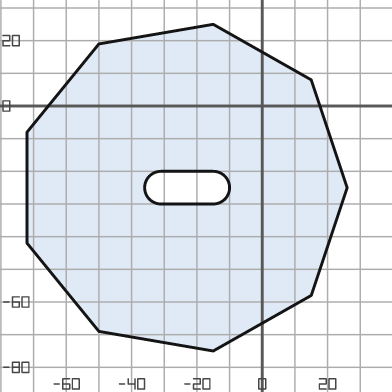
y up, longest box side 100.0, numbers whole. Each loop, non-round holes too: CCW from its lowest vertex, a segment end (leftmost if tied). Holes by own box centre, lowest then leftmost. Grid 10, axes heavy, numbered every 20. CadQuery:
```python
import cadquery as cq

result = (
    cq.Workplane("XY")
    .moveTo(-15.0, -75.0)
    .lineTo(15.0, -58.0)
    .lineTo(26.0, -25.0)
    .lineTo(15.0, 8.0)
    .lineTo(-15.0, 25.0)
    .lineTo(-50.0, 19.0)
    .lineTo(-72.0, -8.0)
    .lineTo(-72.0, -42.0)
    .lineTo(-50.0, -69.0)
    .close()
    .moveTo(-31.0, -30.0)
    .lineTo(-15.0, -30.0)
    .threePointArc((-10.0, -25.0), (-15.0, -20.0))
    .lineTo(-31.0, -20.0)
    .threePointArc((-36.0, -25.0), (-31.0, -30.0))
    .close()
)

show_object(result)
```